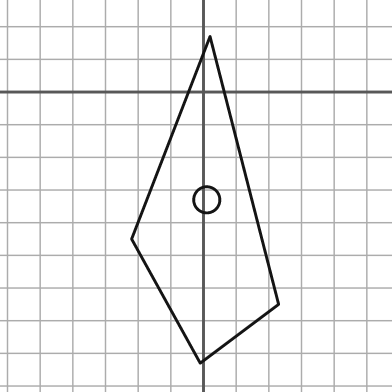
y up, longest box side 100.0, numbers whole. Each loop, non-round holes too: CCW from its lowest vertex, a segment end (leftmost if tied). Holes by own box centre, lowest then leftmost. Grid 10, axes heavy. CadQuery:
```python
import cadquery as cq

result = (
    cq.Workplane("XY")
    .moveTo(-1.0, -83.0)
    .lineTo(23.0, -65.0)
    .lineTo(2.0, 17.0)
    .lineTo(-22.0, -45.0)
    .close()
    .moveTo(1.0, -33.0)
    .circle(4.0)
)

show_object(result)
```